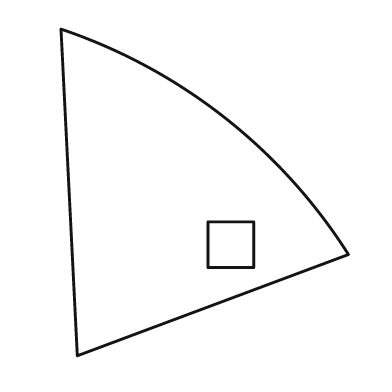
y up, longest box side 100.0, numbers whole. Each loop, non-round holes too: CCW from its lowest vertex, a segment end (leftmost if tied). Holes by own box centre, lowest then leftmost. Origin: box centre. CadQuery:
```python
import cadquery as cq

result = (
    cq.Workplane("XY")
    .moveTo(-39.0, -50.0)
    .lineTo(44.0, -19.0)
    .threePointArc((6.0, 23.0), (-44.0, 50.0))
    .close()
    .moveTo(1.0, -23.0)
    .lineTo(15.0, -23.0)
    .lineTo(15.0, -9.0)
    .lineTo(1.0, -9.0)
    .close()
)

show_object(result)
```